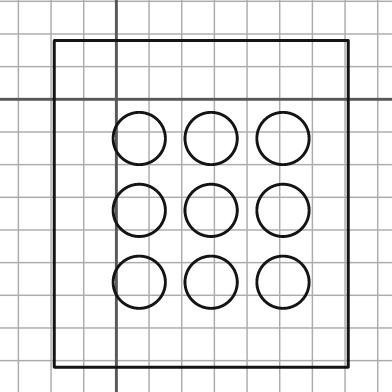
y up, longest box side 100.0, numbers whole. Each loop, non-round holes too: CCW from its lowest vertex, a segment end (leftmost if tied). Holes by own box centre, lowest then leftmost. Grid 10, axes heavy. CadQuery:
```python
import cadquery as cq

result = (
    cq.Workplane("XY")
    .moveTo(-19.0, -82.0)
    .lineTo(71.0, -82.0)
    .lineTo(71.0, 18.0)
    .lineTo(-19.0, 18.0)
    .close()
    .moveTo(7.0, -56.0)
    .circle(8.0)
    .moveTo(29.0, -56.0)
    .circle(8.0)
    .moveTo(51.0, -56.0)
    .circle(8.0)
    .moveTo(7.0, -34.0)
    .circle(8.0)
    .moveTo(29.0, -34.0)
    .circle(8.0)
    .moveTo(51.0, -34.0)
    .circle(8.0)
    .moveTo(7.0, -12.0)
    .circle(8.0)
    .moveTo(29.0, -12.0)
    .circle(8.0)
    .moveTo(51.0, -12.0)
    .circle(8.0)
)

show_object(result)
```